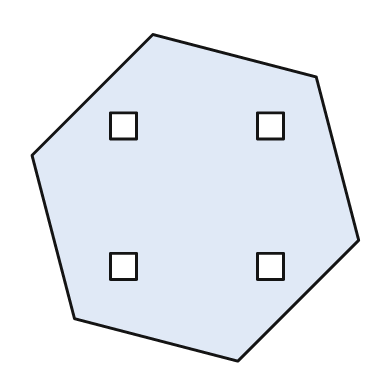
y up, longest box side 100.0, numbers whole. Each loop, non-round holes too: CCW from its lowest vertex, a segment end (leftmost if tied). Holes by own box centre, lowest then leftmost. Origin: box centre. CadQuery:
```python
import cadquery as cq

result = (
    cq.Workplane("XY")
    .moveTo(13.0, -50.0)
    .lineTo(50.0, -13.0)
    .lineTo(37.0, 37.0)
    .lineTo(-13.0, 50.0)
    .lineTo(-50.0, 13.0)
    .lineTo(-37.0, -37.0)
    .close()
    .moveTo(-26.0, -25.0)
    .lineTo(-18.0, -25.0)
    .lineTo(-18.0, -17.0)
    .lineTo(-26.0, -17.0)
    .close()
    .moveTo(19.0, -25.0)
    .lineTo(27.0, -25.0)
    .lineTo(27.0, -17.0)
    .lineTo(19.0, -17.0)
    .close()
    .moveTo(-26.0, 18.0)
    .lineTo(-18.0, 18.0)
    .lineTo(-18.0, 26.0)
    .lineTo(-26.0, 26.0)
    .close()
    .moveTo(19.0, 18.0)
    .lineTo(27.0, 18.0)
    .lineTo(27.0, 26.0)
    .lineTo(19.0, 26.0)
    .close()
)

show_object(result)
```